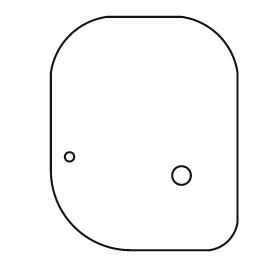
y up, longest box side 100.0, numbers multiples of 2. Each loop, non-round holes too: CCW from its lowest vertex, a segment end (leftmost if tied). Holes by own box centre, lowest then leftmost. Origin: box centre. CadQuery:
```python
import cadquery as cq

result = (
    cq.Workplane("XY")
    .moveTo(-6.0, -50.0)
    .lineTo(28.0, -50.0)
    .threePointArc((36.0, -46.0), (40.0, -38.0))
    .lineTo(40.0, 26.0)
    .threePointArc((32.0, 42.0), (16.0, 50.0))
    .lineTo(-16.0, 50.0)
    .threePointArc((-32.0, 42.0), (-40.0, 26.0))
    .lineTo(-40.0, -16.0)
    .threePointArc((-30.0, -40.0), (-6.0, -50.0))
    .close()
    .moveTo(16.0, -18.0)
    .circle(4.0)
    .moveTo(-32.0, -10.0)
    .circle(2.0)
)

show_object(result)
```